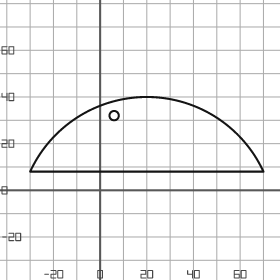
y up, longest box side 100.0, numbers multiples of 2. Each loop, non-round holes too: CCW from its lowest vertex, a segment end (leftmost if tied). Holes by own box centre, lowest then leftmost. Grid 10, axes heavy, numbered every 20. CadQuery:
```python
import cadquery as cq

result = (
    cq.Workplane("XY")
    .moveTo(-30.0, 8.0)
    .lineTo(70.0, 8.0)
    .threePointArc((20.0, 40.0), (-30.0, 8.0))
    .close()
    .moveTo(6.0, 32.0)
    .circle(2.0)
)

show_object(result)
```